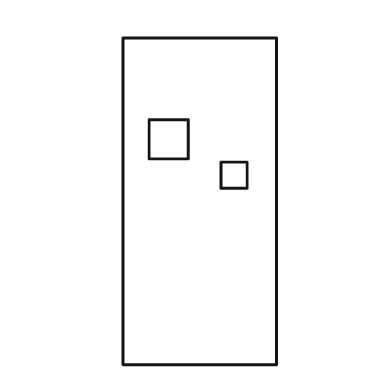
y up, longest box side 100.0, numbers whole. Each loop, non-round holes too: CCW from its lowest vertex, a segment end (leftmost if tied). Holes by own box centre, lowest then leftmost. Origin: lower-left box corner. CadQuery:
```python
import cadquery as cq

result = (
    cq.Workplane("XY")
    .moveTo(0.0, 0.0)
    .lineTo(47.0, 0.0)
    .lineTo(47.0, 100.0)
    .lineTo(0.0, 100.0)
    .close()
    .moveTo(30.0, 54.0)
    .lineTo(38.0, 54.0)
    .lineTo(38.0, 62.0)
    .lineTo(30.0, 62.0)
    .close()
    .moveTo(8.0, 63.0)
    .lineTo(20.0, 63.0)
    .lineTo(20.0, 75.0)
    .lineTo(8.0, 75.0)
    .close()
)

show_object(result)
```